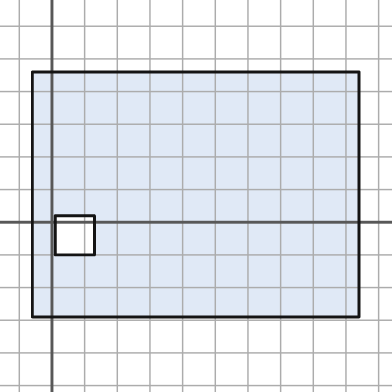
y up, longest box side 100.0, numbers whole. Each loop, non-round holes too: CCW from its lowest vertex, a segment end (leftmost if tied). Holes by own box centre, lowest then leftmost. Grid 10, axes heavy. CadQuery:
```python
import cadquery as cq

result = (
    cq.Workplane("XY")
    .moveTo(-6.0, -29.0)
    .lineTo(94.0, -29.0)
    .lineTo(94.0, 46.0)
    .lineTo(-6.0, 46.0)
    .close()
    .moveTo(1.0, -10.0)
    .lineTo(13.0, -10.0)
    .lineTo(13.0, 2.0)
    .lineTo(1.0, 2.0)
    .close()
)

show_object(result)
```